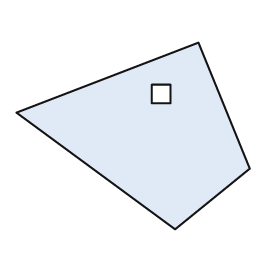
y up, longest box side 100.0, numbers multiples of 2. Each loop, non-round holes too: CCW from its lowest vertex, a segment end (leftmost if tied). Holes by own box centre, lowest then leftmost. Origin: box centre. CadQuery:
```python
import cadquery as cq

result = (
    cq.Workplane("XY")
    .moveTo(18.0, -40.0)
    .lineTo(50.0, -14.0)
    .lineTo(28.0, 40.0)
    .lineTo(-50.0, 10.0)
    .close()
    .moveTo(8.0, 14.0)
    .lineTo(16.0, 14.0)
    .lineTo(16.0, 22.0)
    .lineTo(8.0, 22.0)
    .close()
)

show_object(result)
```